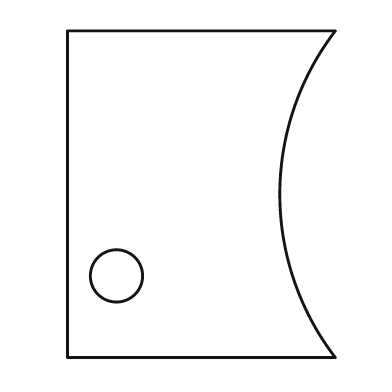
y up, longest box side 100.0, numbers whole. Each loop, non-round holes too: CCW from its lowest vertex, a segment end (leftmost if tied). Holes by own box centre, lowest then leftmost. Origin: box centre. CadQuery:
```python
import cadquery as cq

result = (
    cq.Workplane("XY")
    .moveTo(-41.0, -50.0)
    .lineTo(41.0, -50.0)
    .threePointArc((24.0, 0.0), (41.0, 50.0))
    .lineTo(-41.0, 50.0)
    .close()
    .moveTo(-26.0, -25.0)
    .circle(8.0)
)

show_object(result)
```